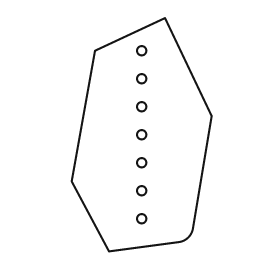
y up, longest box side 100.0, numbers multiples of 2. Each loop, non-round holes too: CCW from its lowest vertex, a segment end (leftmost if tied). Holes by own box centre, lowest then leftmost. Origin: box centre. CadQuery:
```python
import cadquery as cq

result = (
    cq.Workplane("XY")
    .moveTo(-14.0, -50.0)
    .lineTo(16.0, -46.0)
    .threePointArc((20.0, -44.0), (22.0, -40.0))
    .lineTo(30.0, 8.0)
    .lineTo(10.0, 50.0)
    .lineTo(-20.0, 36.0)
    .lineTo(-30.0, -20.0)
    .close()
    .moveTo(0.0, -36.0)
    .circle(2.0)
    .moveTo(0.0, -24.0)
    .circle(2.0)
    .moveTo(0.0, -12.0)
    .circle(2.0)
    .moveTo(0.0, 0.0)
    .circle(2.0)
    .moveTo(0.0, 12.0)
    .circle(2.0)
    .moveTo(0.0, 24.0)
    .circle(2.0)
    .moveTo(0.0, 36.0)
    .circle(2.0)
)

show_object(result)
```